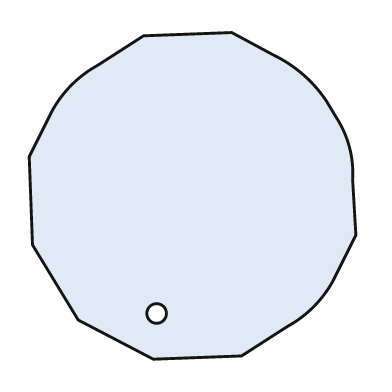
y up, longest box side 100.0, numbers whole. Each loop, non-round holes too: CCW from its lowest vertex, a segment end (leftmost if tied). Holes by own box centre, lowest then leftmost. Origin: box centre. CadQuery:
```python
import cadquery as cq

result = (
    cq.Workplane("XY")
    .moveTo(-12.0, -50.0)
    .lineTo(15.0, -49.0)
    .lineTo(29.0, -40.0)
    .threePointArc((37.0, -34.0), (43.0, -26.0))
    .lineTo(50.0, -12.0)
    .lineTo(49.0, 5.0)
    .threePointArc((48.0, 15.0), (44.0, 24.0))
    .lineTo(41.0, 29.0)
    .threePointArc((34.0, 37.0), (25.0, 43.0))
    .lineTo(12.0, 50.0)
    .lineTo(-15.0, 49.0)
    .lineTo(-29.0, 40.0)
    .threePointArc((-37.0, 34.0), (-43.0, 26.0))
    .lineTo(-50.0, 12.0)
    .lineTo(-49.0, -15.0)
    .lineTo(-35.0, -38.0)
    .close()
    .moveTo(-11.0, -36.0)
    .circle(3.0)
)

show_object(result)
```